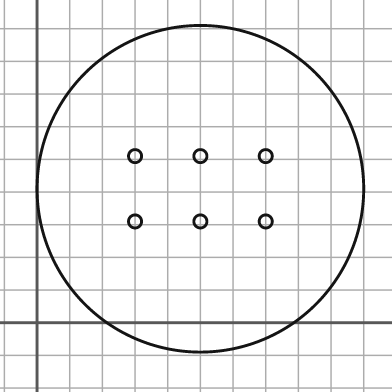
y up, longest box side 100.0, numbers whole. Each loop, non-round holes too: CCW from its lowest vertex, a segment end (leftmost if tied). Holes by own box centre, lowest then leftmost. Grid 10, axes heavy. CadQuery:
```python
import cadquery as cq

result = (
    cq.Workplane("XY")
    .moveTo(50.0, 41.0)
    .circle(50.0)
    .moveTo(30.0, 31.0)
    .circle(2.0)
    .moveTo(50.0, 31.0)
    .circle(2.0)
    .moveTo(70.0, 31.0)
    .circle(2.0)
    .moveTo(30.0, 51.0)
    .circle(2.0)
    .moveTo(50.0, 51.0)
    .circle(2.0)
    .moveTo(70.0, 51.0)
    .circle(2.0)
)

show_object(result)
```